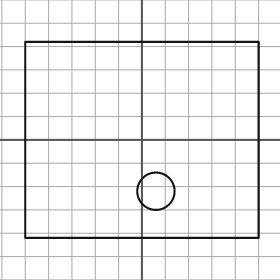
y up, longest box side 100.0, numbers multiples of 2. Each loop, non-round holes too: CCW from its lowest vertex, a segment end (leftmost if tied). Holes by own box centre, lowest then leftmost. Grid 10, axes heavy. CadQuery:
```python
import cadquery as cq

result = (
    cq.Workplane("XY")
    .moveTo(-50.0, -42.0)
    .lineTo(50.0, -42.0)
    .lineTo(50.0, 42.0)
    .lineTo(-50.0, 42.0)
    .close()
    .moveTo(6.0, -22.0)
    .circle(8.0)
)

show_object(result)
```